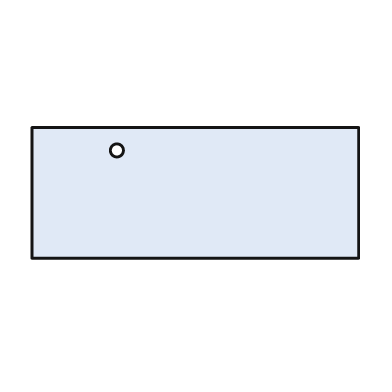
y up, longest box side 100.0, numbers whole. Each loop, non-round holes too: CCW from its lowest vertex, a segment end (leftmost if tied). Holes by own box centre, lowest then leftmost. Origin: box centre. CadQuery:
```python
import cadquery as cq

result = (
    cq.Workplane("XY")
    .moveTo(-50.0, -20.0)
    .lineTo(50.0, -20.0)
    .lineTo(50.0, 20.0)
    .lineTo(-50.0, 20.0)
    .close()
    .moveTo(-24.0, 13.0)
    .circle(2.0)
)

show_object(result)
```